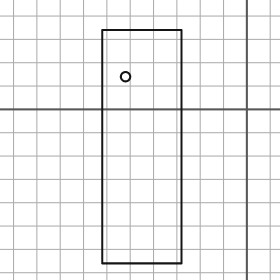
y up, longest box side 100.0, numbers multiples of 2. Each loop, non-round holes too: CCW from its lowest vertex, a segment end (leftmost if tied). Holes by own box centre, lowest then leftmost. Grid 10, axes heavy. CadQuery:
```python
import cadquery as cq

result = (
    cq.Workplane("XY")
    .moveTo(-62.0, -66.0)
    .lineTo(-28.0, -66.0)
    .lineTo(-28.0, 34.0)
    .lineTo(-62.0, 34.0)
    .close()
    .moveTo(-52.0, 14.0)
    .circle(2.0)
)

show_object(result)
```